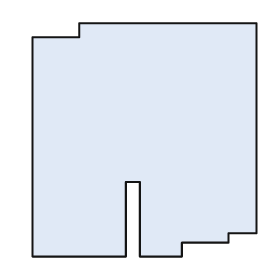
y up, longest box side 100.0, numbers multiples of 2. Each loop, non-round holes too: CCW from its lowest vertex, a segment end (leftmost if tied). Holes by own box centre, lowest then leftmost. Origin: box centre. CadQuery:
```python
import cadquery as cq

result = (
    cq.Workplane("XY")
    .moveTo(-48.0, -50.0)
    .lineTo(-8.0, -50.0)
    .lineTo(-8.0, -18.0)
    .lineTo(-2.0, -18.0)
    .lineTo(-2.0, -50.0)
    .lineTo(16.0, -50.0)
    .lineTo(16.0, -44.0)
    .lineTo(36.0, -44.0)
    .lineTo(36.0, -40.0)
    .lineTo(48.0, -40.0)
    .lineTo(48.0, 50.0)
    .lineTo(-28.0, 50.0)
    .lineTo(-28.0, 44.0)
    .lineTo(-48.0, 44.0)
    .close()
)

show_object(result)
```